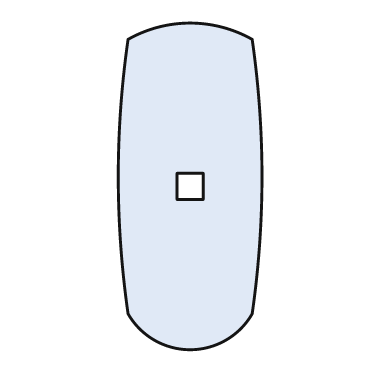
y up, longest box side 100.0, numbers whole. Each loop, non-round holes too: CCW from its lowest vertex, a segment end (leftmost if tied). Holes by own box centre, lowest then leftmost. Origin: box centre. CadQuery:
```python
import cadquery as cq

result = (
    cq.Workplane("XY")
    .moveTo(-19.0, -39.0)
    .threePointArc((0.0, -50.0), (19.0, -39.0))
    .threePointArc((22.0, 3.0), (19.0, 45.0))
    .threePointArc((0.0, 50.0), (-19.0, 45.0))
    .threePointArc((-22.0, 3.0), (-19.0, -39.0))
    .close()
    .moveTo(-4.0, -4.0)
    .lineTo(4.0, -4.0)
    .lineTo(4.0, 4.0)
    .lineTo(-4.0, 4.0)
    .close()
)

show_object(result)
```